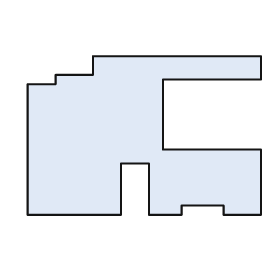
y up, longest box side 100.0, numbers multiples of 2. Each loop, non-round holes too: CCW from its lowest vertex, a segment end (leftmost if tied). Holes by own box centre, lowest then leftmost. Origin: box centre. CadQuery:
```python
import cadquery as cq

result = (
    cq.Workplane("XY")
    .moveTo(-50.0, -34.0)
    .lineTo(-10.0, -34.0)
    .lineTo(-10.0, -12.0)
    .lineTo(2.0, -12.0)
    .lineTo(2.0, -34.0)
    .lineTo(16.0, -34.0)
    .lineTo(16.0, -30.0)
    .lineTo(34.0, -30.0)
    .lineTo(34.0, -34.0)
    .lineTo(50.0, -34.0)
    .lineTo(50.0, -6.0)
    .lineTo(8.0, -6.0)
    .lineTo(8.0, 24.0)
    .lineTo(50.0, 24.0)
    .lineTo(50.0, 34.0)
    .lineTo(-22.0, 34.0)
    .lineTo(-22.0, 26.0)
    .lineTo(-38.0, 26.0)
    .lineTo(-38.0, 22.0)
    .lineTo(-50.0, 22.0)
    .close()
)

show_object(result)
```